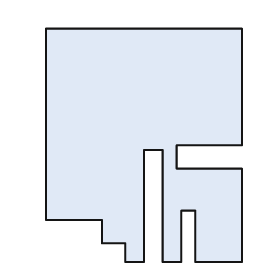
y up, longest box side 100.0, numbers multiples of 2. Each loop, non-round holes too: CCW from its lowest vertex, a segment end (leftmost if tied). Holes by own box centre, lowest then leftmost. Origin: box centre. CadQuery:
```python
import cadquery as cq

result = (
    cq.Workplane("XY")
    .moveTo(-8.0, -50.0)
    .lineTo(0.0, -50.0)
    .lineTo(0.0, -2.0)
    .lineTo(8.0, -2.0)
    .lineTo(8.0, -50.0)
    .lineTo(16.0, -50.0)
    .lineTo(16.0, -28.0)
    .lineTo(22.0, -28.0)
    .lineTo(22.0, -50.0)
    .lineTo(42.0, -50.0)
    .lineTo(42.0, -10.0)
    .lineTo(14.0, -10.0)
    .lineTo(14.0, 0.0)
    .lineTo(42.0, 0.0)
    .lineTo(42.0, 50.0)
    .lineTo(-42.0, 50.0)
    .lineTo(-42.0, -32.0)
    .lineTo(-18.0, -32.0)
    .lineTo(-18.0, -42.0)
    .lineTo(-8.0, -42.0)
    .close()
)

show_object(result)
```